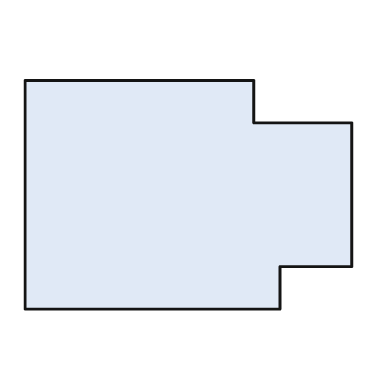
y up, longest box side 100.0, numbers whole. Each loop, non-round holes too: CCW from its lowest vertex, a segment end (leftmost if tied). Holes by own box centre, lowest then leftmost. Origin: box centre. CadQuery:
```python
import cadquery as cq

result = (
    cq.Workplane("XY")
    .moveTo(-50.0, -35.0)
    .lineTo(28.0, -35.0)
    .lineTo(28.0, -22.0)
    .lineTo(50.0, -22.0)
    .lineTo(50.0, 22.0)
    .lineTo(20.0, 22.0)
    .lineTo(20.0, 35.0)
    .lineTo(-50.0, 35.0)
    .close()
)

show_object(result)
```